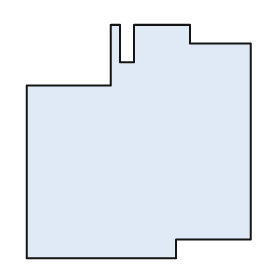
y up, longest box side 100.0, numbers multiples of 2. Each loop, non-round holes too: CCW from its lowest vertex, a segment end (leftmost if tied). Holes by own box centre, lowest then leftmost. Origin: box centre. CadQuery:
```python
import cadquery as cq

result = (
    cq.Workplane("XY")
    .moveTo(-48.0, -50.0)
    .lineTo(16.0, -50.0)
    .lineTo(16.0, -42.0)
    .lineTo(48.0, -42.0)
    .lineTo(48.0, 42.0)
    .lineTo(22.0, 42.0)
    .lineTo(22.0, 50.0)
    .lineTo(-2.0, 50.0)
    .lineTo(-2.0, 34.0)
    .lineTo(-8.0, 34.0)
    .lineTo(-8.0, 50.0)
    .lineTo(-12.0, 50.0)
    .lineTo(-12.0, 24.0)
    .lineTo(-48.0, 24.0)
    .close()
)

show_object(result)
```